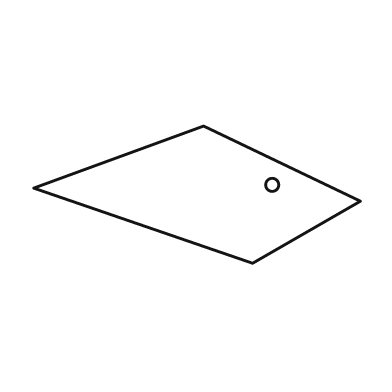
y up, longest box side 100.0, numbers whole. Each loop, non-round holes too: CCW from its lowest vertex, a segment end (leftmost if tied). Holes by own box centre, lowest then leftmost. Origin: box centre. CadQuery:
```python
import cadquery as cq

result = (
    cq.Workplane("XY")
    .moveTo(17.0, -21.0)
    .lineTo(50.0, -2.0)
    .lineTo(2.0, 21.0)
    .lineTo(-50.0, 2.0)
    .close()
    .moveTo(23.0, 3.0)
    .circle(2.0)
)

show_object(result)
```